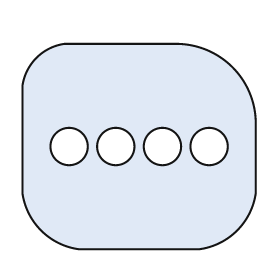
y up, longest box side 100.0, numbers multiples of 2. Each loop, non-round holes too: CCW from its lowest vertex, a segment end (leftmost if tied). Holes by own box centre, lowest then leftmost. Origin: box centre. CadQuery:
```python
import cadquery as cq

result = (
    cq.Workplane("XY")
    .moveTo(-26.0, -44.0)
    .lineTo(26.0, -44.0)
    .threePointArc((42.0, -36.0), (50.0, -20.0))
    .lineTo(50.0, 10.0)
    .threePointArc((40.0, 34.0), (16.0, 44.0))
    .lineTo(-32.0, 44.0)
    .threePointArc((-44.0, 38.0), (-50.0, 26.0))
    .lineTo(-50.0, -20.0)
    .threePointArc((-42.0, -36.0), (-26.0, -44.0))
    .close()
    .moveTo(-30.0, 0.0)
    .circle(8.0)
    .moveTo(-10.0, 0.0)
    .circle(8.0)
    .moveTo(10.0, 0.0)
    .circle(8.0)
    .moveTo(30.0, 0.0)
    .circle(8.0)
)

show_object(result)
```